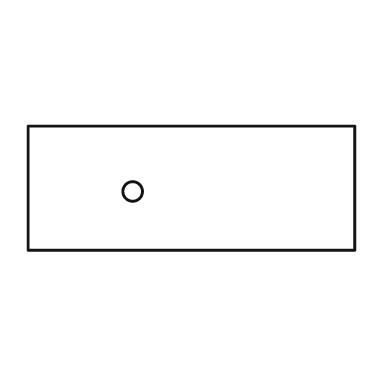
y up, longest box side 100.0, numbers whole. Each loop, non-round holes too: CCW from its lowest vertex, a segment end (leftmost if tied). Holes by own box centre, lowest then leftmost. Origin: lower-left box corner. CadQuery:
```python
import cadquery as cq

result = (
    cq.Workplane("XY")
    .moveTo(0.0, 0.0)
    .lineTo(100.0, 0.0)
    .lineTo(100.0, 38.0)
    .lineTo(0.0, 38.0)
    .close()
    .moveTo(32.0, 18.0)
    .circle(3.0)
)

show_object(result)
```